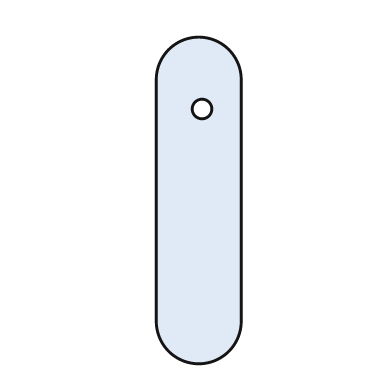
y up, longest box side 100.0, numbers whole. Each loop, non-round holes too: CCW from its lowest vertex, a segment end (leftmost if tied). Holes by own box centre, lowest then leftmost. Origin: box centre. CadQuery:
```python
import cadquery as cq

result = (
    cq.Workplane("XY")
    .moveTo(-13.0, -37.0)
    .threePointArc((0.0, -50.0), (13.0, -37.0))
    .lineTo(13.0, 37.0)
    .threePointArc((0.0, 50.0), (-13.0, 37.0))
    .close()
    .moveTo(1.0, 28.0)
    .circle(3.0)
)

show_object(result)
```